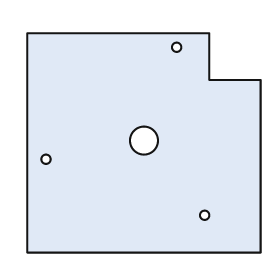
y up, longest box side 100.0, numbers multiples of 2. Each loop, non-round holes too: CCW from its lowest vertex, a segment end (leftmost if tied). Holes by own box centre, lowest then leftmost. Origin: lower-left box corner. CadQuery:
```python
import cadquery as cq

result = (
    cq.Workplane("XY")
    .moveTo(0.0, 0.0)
    .lineTo(100.0, 0.0)
    .lineTo(100.0, 74.0)
    .lineTo(78.0, 74.0)
    .lineTo(78.0, 94.0)
    .lineTo(0.0, 94.0)
    .close()
    .moveTo(76.0, 16.0)
    .circle(2.0)
    .moveTo(8.0, 40.0)
    .circle(2.0)
    .moveTo(50.0, 48.0)
    .circle(6.0)
    .moveTo(64.0, 88.0)
    .circle(2.0)
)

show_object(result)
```